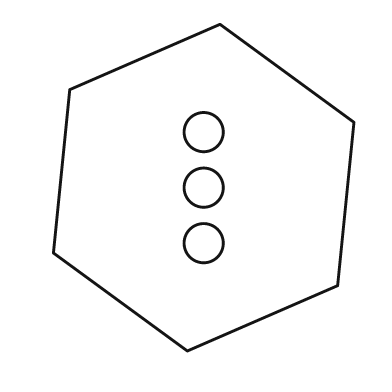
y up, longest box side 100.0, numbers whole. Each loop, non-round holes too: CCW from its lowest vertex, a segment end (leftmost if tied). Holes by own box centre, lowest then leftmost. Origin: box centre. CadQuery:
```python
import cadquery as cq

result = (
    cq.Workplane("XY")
    .moveTo(-5.0, -50.0)
    .lineTo(41.0, -30.0)
    .lineTo(46.0, 20.0)
    .lineTo(5.0, 50.0)
    .lineTo(-41.0, 30.0)
    .lineTo(-46.0, -20.0)
    .close()
    .moveTo(0.0, -17.0)
    .circle(6.0)
    .moveTo(0.0, 0.0)
    .circle(6.0)
    .moveTo(0.0, 17.0)
    .circle(6.0)
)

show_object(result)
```